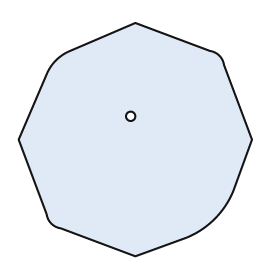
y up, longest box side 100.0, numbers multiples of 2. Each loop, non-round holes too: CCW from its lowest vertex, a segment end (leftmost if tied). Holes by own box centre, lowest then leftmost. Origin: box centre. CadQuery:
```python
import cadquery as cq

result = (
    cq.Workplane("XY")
    .moveTo(0.0, -50.0)
    .lineTo(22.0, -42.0)
    .threePointArc((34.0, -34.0), (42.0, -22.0))
    .lineTo(50.0, 0.0)
    .lineTo(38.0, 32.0)
    .threePointArc((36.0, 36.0), (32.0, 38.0))
    .lineTo(0.0, 50.0)
    .lineTo(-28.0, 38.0)
    .threePointArc((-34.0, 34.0), (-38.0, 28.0))
    .lineTo(-50.0, 0.0)
    .lineTo(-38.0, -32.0)
    .threePointArc((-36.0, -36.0), (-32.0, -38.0))
    .close()
    .moveTo(-2.0, 10.0)
    .circle(2.0)
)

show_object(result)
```